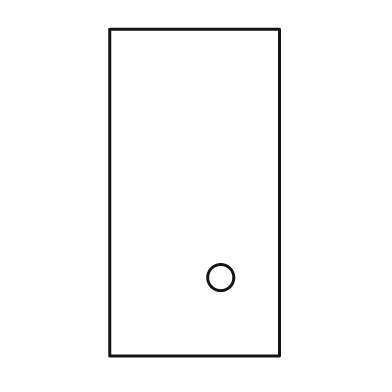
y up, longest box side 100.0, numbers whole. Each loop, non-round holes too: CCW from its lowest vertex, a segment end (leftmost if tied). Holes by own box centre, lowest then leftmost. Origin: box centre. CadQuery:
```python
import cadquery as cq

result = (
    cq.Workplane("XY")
    .moveTo(-26.0, -50.0)
    .lineTo(26.0, -50.0)
    .lineTo(26.0, 50.0)
    .lineTo(-26.0, 50.0)
    .close()
    .moveTo(8.0, -26.0)
    .circle(4.0)
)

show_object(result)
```